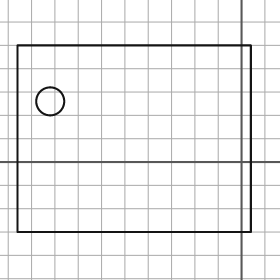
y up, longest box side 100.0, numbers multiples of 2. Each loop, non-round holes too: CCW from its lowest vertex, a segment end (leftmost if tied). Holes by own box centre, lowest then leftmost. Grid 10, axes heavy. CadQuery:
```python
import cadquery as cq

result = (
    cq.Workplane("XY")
    .moveTo(-96.0, -30.0)
    .lineTo(4.0, -30.0)
    .lineTo(4.0, 50.0)
    .lineTo(-96.0, 50.0)
    .close()
    .moveTo(-82.0, 26.0)
    .circle(6.0)
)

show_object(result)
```